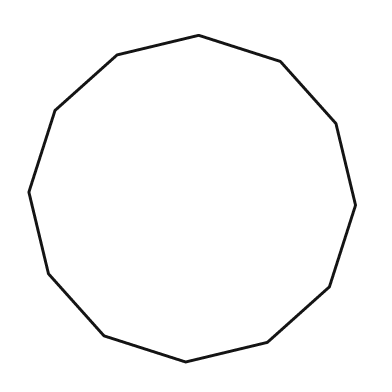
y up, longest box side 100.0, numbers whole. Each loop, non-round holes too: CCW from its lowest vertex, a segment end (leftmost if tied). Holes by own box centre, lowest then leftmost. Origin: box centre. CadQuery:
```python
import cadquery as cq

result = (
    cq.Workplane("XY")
    .moveTo(-2.0, -50.0)
    .lineTo(23.0, -44.0)
    .lineTo(42.0, -27.0)
    .lineTo(50.0, -2.0)
    .lineTo(44.0, 23.0)
    .lineTo(27.0, 42.0)
    .lineTo(2.0, 50.0)
    .lineTo(-23.0, 44.0)
    .lineTo(-42.0, 27.0)
    .lineTo(-50.0, 2.0)
    .lineTo(-44.0, -23.0)
    .lineTo(-27.0, -42.0)
    .close()
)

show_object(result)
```